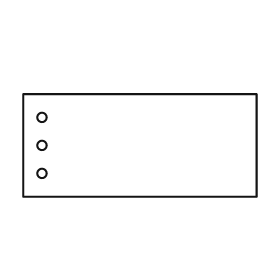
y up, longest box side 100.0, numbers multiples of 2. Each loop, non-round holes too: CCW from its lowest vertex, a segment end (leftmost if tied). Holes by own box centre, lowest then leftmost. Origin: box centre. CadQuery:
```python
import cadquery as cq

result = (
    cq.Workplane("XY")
    .moveTo(-50.0, -22.0)
    .lineTo(50.0, -22.0)
    .lineTo(50.0, 22.0)
    .lineTo(-50.0, 22.0)
    .close()
    .moveTo(-42.0, -12.0)
    .circle(2.0)
    .moveTo(-42.0, 0.0)
    .circle(2.0)
    .moveTo(-42.0, 12.0)
    .circle(2.0)
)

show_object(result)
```